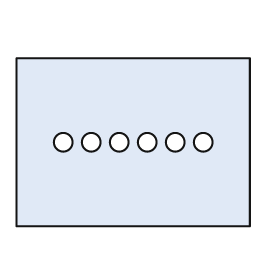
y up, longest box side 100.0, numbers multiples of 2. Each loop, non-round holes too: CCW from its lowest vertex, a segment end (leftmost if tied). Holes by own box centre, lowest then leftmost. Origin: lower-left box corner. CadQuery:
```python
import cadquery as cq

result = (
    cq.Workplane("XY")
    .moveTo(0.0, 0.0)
    .lineTo(100.0, 0.0)
    .lineTo(100.0, 72.0)
    .lineTo(0.0, 72.0)
    .close()
    .moveTo(20.0, 36.0)
    .circle(4.0)
    .moveTo(32.0, 36.0)
    .circle(4.0)
    .moveTo(44.0, 36.0)
    .circle(4.0)
    .moveTo(56.0, 36.0)
    .circle(4.0)
    .moveTo(68.0, 36.0)
    .circle(4.0)
    .moveTo(80.0, 36.0)
    .circle(4.0)
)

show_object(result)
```